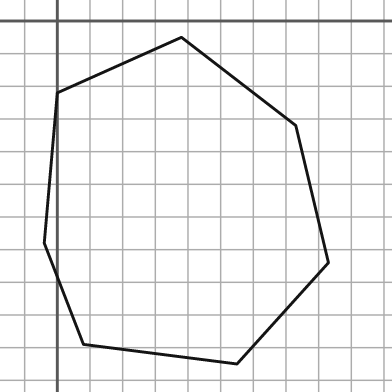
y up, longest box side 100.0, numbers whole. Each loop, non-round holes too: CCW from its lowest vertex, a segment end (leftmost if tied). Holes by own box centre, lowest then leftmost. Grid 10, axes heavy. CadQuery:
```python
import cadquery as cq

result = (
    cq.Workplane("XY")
    .moveTo(55.0, -105.0)
    .lineTo(83.0, -74.0)
    .lineTo(73.0, -32.0)
    .lineTo(38.0, -5.0)
    .lineTo(0.0, -22.0)
    .lineTo(-4.0, -68.0)
    .lineTo(8.0, -99.0)
    .close()
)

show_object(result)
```